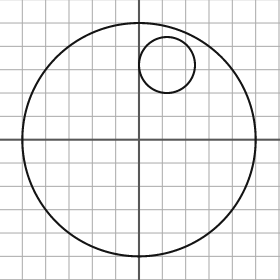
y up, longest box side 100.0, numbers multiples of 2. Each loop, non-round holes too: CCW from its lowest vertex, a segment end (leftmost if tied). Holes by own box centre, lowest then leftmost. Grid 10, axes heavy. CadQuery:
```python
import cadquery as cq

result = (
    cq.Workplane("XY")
    .moveTo(0.0, 0.0)
    .circle(50.0)
    .moveTo(12.0, 32.0)
    .circle(12.0)
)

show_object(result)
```